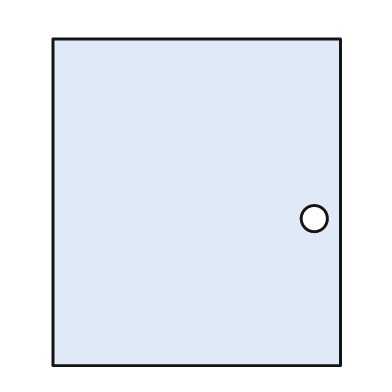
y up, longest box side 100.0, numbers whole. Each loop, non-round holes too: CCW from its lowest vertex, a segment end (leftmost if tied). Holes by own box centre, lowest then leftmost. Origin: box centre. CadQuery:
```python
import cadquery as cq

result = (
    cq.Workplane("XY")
    .moveTo(-44.0, -50.0)
    .lineTo(44.0, -50.0)
    .lineTo(44.0, 50.0)
    .lineTo(-44.0, 50.0)
    .close()
    .moveTo(36.0, -5.0)
    .circle(4.0)
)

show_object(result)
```